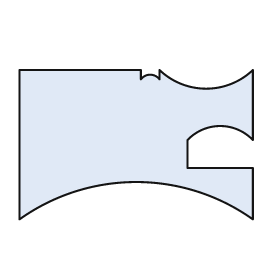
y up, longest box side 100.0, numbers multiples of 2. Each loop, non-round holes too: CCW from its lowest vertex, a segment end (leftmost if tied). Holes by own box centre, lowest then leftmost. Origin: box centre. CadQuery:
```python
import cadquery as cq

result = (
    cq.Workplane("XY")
    .moveTo(-50.0, -32.0)
    .threePointArc((0.0, -16.0), (50.0, -32.0))
    .lineTo(50.0, -10.0)
    .lineTo(22.0, -10.0)
    .lineTo(22.0, 2.0)
    .threePointArc((36.0, 8.0), (50.0, 2.0))
    .lineTo(50.0, 32.0)
    .threePointArc((30.0, 24.0), (10.0, 32.0))
    .lineTo(10.0, 28.0)
    .threePointArc((6.0, 30.0), (2.0, 28.0))
    .lineTo(2.0, 32.0)
    .lineTo(-50.0, 32.0)
    .close()
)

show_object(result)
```